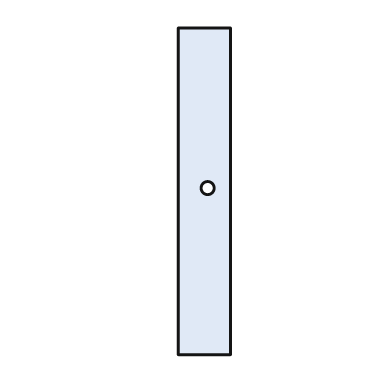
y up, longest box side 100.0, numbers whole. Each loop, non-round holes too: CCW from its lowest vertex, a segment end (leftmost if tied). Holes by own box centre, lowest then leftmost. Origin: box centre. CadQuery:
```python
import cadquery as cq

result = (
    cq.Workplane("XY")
    .moveTo(-8.0, -50.0)
    .lineTo(8.0, -50.0)
    .lineTo(8.0, 50.0)
    .lineTo(-8.0, 50.0)
    .close()
    .moveTo(1.0, 1.0)
    .circle(2.0)
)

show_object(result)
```